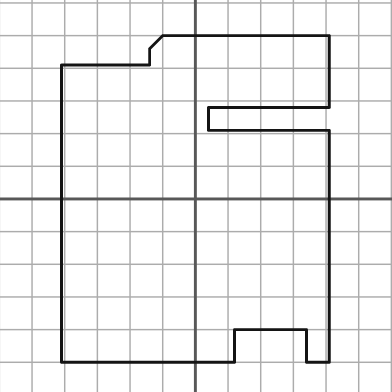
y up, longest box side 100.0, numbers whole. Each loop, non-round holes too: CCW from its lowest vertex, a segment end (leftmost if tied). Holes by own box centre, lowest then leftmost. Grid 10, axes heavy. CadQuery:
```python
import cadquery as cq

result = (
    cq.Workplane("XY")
    .moveTo(-41.0, -50.0)
    .lineTo(12.0, -50.0)
    .lineTo(12.0, -40.0)
    .lineTo(34.0, -40.0)
    .lineTo(34.0, -50.0)
    .lineTo(41.0, -50.0)
    .lineTo(41.0, 21.0)
    .lineTo(4.0, 21.0)
    .lineTo(4.0, 28.0)
    .lineTo(41.0, 28.0)
    .lineTo(41.0, 50.0)
    .lineTo(-10.0, 50.0)
    .lineTo(-14.0, 46.0)
    .lineTo(-14.0, 41.0)
    .lineTo(-41.0, 41.0)
    .close()
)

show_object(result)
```